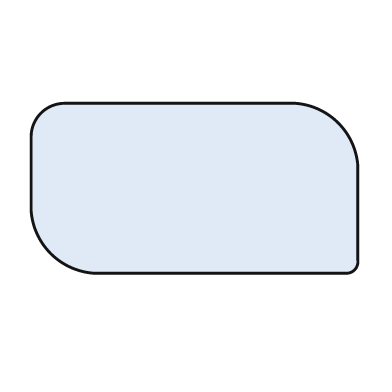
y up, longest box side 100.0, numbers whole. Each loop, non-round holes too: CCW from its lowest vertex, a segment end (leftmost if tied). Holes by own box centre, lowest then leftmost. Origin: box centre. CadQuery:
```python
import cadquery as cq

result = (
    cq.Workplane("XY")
    .moveTo(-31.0, -26.0)
    .lineTo(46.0, -26.0)
    .threePointArc((49.0, -25.0), (50.0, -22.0))
    .lineTo(50.0, 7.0)
    .threePointArc((44.0, 20.0), (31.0, 26.0))
    .lineTo(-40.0, 26.0)
    .threePointArc((-47.0, 23.0), (-50.0, 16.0))
    .lineTo(-50.0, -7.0)
    .threePointArc((-44.0, -20.0), (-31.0, -26.0))
    .close()
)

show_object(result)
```